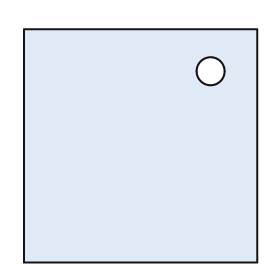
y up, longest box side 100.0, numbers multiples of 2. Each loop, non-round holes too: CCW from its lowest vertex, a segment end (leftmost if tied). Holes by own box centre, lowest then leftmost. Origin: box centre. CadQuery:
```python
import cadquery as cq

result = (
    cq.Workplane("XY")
    .moveTo(-50.0, -50.0)
    .lineTo(50.0, -50.0)
    .lineTo(50.0, 50.0)
    .lineTo(-50.0, 50.0)
    .close()
    .moveTo(30.0, 32.0)
    .circle(6.0)
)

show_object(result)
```